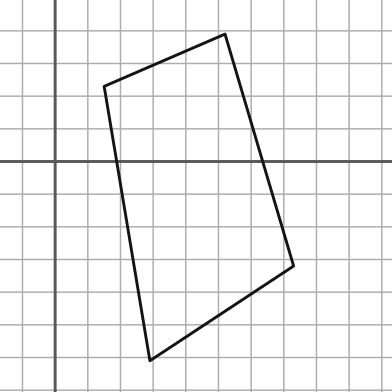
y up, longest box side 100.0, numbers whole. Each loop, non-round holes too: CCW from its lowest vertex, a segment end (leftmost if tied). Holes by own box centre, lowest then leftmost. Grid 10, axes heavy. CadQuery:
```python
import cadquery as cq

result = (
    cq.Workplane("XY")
    .moveTo(29.0, -61.0)
    .lineTo(73.0, -32.0)
    .lineTo(52.0, 39.0)
    .lineTo(15.0, 23.0)
    .close()
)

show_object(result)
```